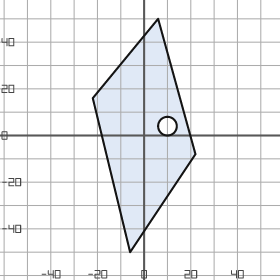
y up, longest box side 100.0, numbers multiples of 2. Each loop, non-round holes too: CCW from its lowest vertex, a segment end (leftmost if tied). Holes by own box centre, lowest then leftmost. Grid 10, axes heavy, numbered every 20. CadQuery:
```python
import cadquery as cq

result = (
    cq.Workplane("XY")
    .moveTo(-6.0, -50.0)
    .lineTo(22.0, -8.0)
    .lineTo(6.0, 50.0)
    .lineTo(-22.0, 16.0)
    .close()
    .moveTo(10.0, 4.0)
    .circle(4.0)
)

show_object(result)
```